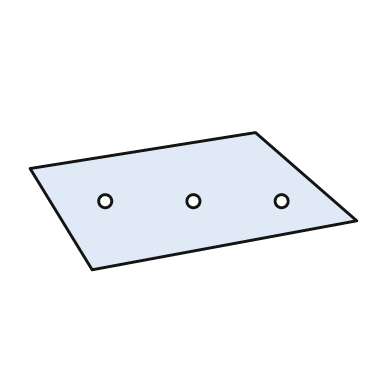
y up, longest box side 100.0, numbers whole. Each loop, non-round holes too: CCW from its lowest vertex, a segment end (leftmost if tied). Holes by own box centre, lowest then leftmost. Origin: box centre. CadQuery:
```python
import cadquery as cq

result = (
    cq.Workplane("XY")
    .moveTo(-31.0, -21.0)
    .lineTo(50.0, -6.0)
    .lineTo(19.0, 21.0)
    .lineTo(-50.0, 10.0)
    .close()
    .moveTo(-27.0, 0.0)
    .circle(2.0)
    .moveTo(0.0, 0.0)
    .circle(2.0)
    .moveTo(27.0, 0.0)
    .circle(2.0)
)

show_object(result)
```